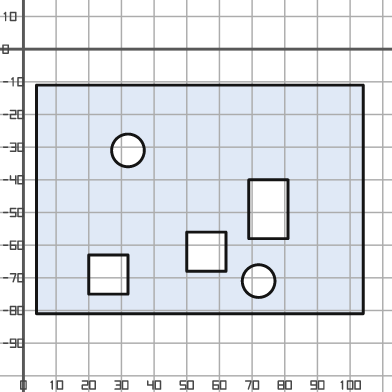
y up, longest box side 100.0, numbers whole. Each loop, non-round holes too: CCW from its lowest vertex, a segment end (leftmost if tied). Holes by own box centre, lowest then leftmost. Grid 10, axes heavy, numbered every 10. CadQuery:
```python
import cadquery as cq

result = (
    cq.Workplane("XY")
    .moveTo(4.0, -81.0)
    .lineTo(104.0, -81.0)
    .lineTo(104.0, -11.0)
    .lineTo(4.0, -11.0)
    .close()
    .moveTo(72.0, -71.0)
    .circle(5.0)
    .moveTo(20.0, -75.0)
    .lineTo(32.0, -75.0)
    .lineTo(32.0, -63.0)
    .lineTo(20.0, -63.0)
    .close()
    .moveTo(50.0, -68.0)
    .lineTo(62.0, -68.0)
    .lineTo(62.0, -56.0)
    .lineTo(50.0, -56.0)
    .close()
    .moveTo(69.0, -58.0)
    .lineTo(81.0, -58.0)
    .lineTo(81.0, -40.0)
    .lineTo(69.0, -40.0)
    .close()
    .moveTo(32.0, -31.0)
    .circle(5.0)
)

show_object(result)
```